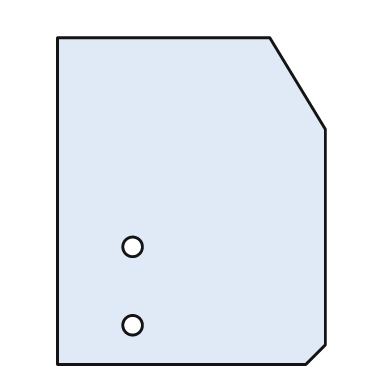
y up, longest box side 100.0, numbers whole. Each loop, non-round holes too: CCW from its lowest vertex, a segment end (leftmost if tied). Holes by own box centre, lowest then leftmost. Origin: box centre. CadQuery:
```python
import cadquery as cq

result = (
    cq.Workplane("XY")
    .moveTo(-41.0, -50.0)
    .lineTo(35.0, -50.0)
    .lineTo(41.0, -44.0)
    .lineTo(41.0, 22.0)
    .lineTo(24.0, 50.0)
    .lineTo(-41.0, 50.0)
    .close()
    .moveTo(-18.0, -38.0)
    .circle(3.0)
    .moveTo(-18.0, -14.0)
    .circle(3.0)
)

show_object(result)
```